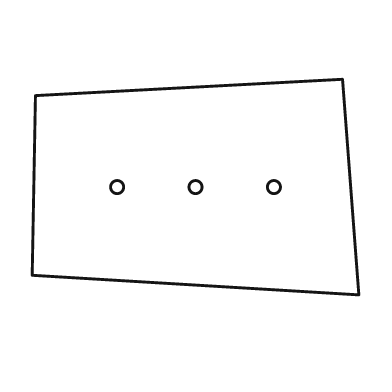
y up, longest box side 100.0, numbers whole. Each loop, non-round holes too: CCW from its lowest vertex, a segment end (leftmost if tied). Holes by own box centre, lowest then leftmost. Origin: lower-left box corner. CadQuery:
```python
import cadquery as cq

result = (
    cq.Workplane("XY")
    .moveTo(100.0, 0.0)
    .lineTo(95.0, 66.0)
    .lineTo(1.0, 61.0)
    .lineTo(0.0, 6.0)
    .close()
    .moveTo(26.0, 33.0)
    .circle(2.0)
    .moveTo(50.0, 33.0)
    .circle(2.0)
    .moveTo(74.0, 33.0)
    .circle(2.0)
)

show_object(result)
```